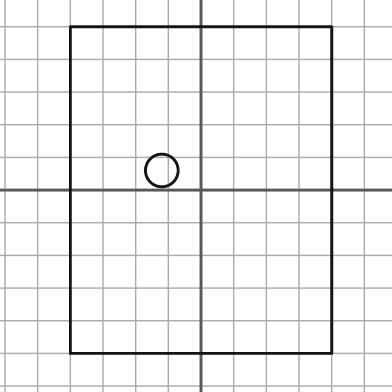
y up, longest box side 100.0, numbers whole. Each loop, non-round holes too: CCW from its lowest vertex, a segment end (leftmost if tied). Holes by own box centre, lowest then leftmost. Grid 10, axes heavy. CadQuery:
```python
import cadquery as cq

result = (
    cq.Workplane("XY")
    .moveTo(-40.0, -50.0)
    .lineTo(40.0, -50.0)
    .lineTo(40.0, 50.0)
    .lineTo(-40.0, 50.0)
    .close()
    .moveTo(-12.0, 6.0)
    .circle(5.0)
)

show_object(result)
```